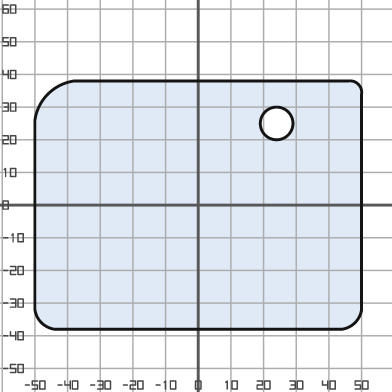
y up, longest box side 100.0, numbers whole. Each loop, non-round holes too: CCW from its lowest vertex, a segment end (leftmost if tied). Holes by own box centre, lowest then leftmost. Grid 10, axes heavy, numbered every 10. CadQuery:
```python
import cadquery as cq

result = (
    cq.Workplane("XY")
    .moveTo(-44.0, -38.0)
    .lineTo(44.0, -38.0)
    .threePointArc((48.0, -36.0), (50.0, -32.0))
    .lineTo(50.0, 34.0)
    .threePointArc((49.0, 37.0), (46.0, 38.0))
    .lineTo(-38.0, 38.0)
    .threePointArc((-46.0, 34.0), (-50.0, 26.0))
    .lineTo(-50.0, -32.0)
    .threePointArc((-48.0, -36.0), (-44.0, -38.0))
    .close()
    .moveTo(24.0, 25.0)
    .circle(5.0)
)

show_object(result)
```